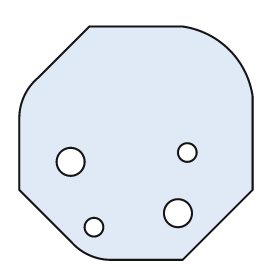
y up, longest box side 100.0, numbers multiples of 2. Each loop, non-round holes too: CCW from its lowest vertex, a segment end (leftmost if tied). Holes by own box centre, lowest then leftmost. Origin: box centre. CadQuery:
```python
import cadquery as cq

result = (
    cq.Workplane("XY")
    .moveTo(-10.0, -50.0)
    .lineTo(20.0, -50.0)
    .lineTo(50.0, -20.0)
    .lineTo(50.0, 20.0)
    .threePointArc((40.0, 40.0), (20.0, 50.0))
    .lineTo(-20.0, 50.0)
    .lineTo(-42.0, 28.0)
    .threePointArc((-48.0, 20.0), (-50.0, 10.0))
    .lineTo(-50.0, -20.0)
    .lineTo(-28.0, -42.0)
    .threePointArc((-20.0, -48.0), (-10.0, -50.0))
    .close()
    .moveTo(-18.0, -36.0)
    .circle(4.0)
    .moveTo(18.0, -30.0)
    .circle(6.0)
    .moveTo(-28.0, -8.0)
    .circle(6.0)
    .moveTo(22.0, -4.0)
    .circle(4.0)
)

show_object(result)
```